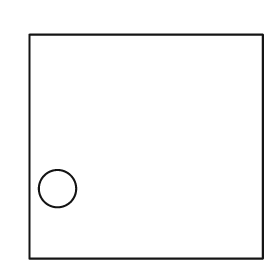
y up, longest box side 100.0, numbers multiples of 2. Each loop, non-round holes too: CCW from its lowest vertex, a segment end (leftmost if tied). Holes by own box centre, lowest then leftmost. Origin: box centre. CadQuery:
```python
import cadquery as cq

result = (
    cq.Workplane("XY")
    .moveTo(-50.0, -48.0)
    .lineTo(50.0, -48.0)
    .lineTo(50.0, 48.0)
    .lineTo(-50.0, 48.0)
    .close()
    .moveTo(-38.0, -18.0)
    .circle(8.0)
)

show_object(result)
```